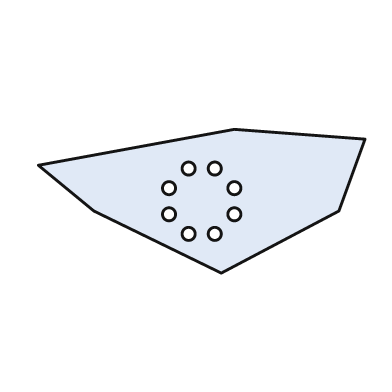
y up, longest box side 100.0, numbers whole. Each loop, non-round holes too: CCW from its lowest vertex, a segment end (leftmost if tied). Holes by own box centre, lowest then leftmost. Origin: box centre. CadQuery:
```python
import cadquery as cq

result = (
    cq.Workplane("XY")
    .moveTo(6.0, -22.0)
    .lineTo(42.0, -3.0)
    .lineTo(50.0, 19.0)
    .lineTo(10.0, 22.0)
    .lineTo(-50.0, 11.0)
    .lineTo(-33.0, -3.0)
    .close()
    .moveTo(-4.0, -10.0)
    .circle(2.0)
    .moveTo(4.0, -10.0)
    .circle(2.0)
    .moveTo(-10.0, -4.0)
    .circle(2.0)
    .moveTo(10.0, -4.0)
    .circle(2.0)
    .moveTo(-10.0, 4.0)
    .circle(2.0)
    .moveTo(10.0, 4.0)
    .circle(2.0)
    .moveTo(-4.0, 10.0)
    .circle(2.0)
    .moveTo(4.0, 10.0)
    .circle(2.0)
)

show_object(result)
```